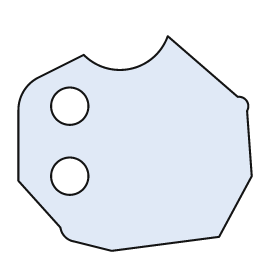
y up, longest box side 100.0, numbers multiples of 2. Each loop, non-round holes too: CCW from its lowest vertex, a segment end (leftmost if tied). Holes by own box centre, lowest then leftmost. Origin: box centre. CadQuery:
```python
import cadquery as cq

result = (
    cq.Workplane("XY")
    .moveTo(-10.0, -46.0)
    .lineTo(36.0, -40.0)
    .lineTo(50.0, -14.0)
    .lineTo(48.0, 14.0)
    .threePointArc((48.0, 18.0), (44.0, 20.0))
    .lineTo(14.0, 46.0)
    .threePointArc((-2.0, 32.0), (-22.0, 38.0))
    .lineTo(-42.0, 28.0)
    .threePointArc((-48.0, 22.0), (-50.0, 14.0))
    .lineTo(-50.0, -16.0)
    .lineTo(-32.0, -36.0)
    .threePointArc((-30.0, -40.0), (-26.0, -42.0))
    .close()
    .moveTo(-28.0, -14.0)
    .circle(8.0)
    .moveTo(-28.0, 16.0)
    .circle(8.0)
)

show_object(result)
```